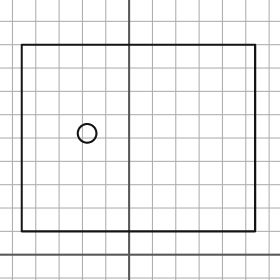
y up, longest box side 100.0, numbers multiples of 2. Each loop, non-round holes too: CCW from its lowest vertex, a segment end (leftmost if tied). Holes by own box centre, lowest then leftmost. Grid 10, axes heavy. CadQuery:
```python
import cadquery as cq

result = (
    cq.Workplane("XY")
    .moveTo(-46.0, 10.0)
    .lineTo(54.0, 10.0)
    .lineTo(54.0, 90.0)
    .lineTo(-46.0, 90.0)
    .close()
    .moveTo(-18.0, 52.0)
    .circle(4.0)
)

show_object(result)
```